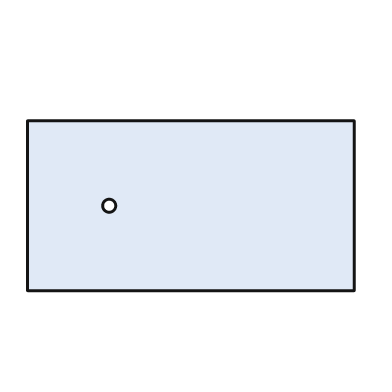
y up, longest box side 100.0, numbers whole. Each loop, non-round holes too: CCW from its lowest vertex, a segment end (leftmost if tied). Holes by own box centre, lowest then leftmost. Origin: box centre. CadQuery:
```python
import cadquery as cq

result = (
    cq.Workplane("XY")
    .moveTo(-50.0, -26.0)
    .lineTo(50.0, -26.0)
    .lineTo(50.0, 26.0)
    .lineTo(-50.0, 26.0)
    .close()
    .moveTo(-25.0, 0.0)
    .circle(2.0)
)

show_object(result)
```